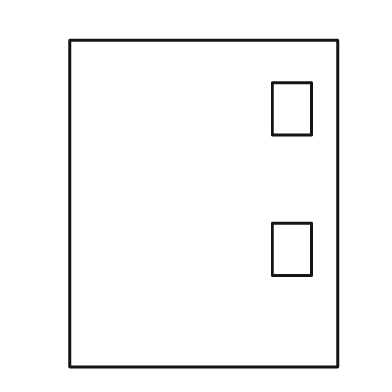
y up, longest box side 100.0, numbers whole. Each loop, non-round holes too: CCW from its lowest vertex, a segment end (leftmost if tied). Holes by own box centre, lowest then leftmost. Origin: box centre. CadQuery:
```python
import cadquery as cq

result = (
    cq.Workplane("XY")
    .moveTo(-41.0, -50.0)
    .lineTo(41.0, -50.0)
    .lineTo(41.0, 50.0)
    .lineTo(-41.0, 50.0)
    .close()
    .moveTo(21.0, -22.0)
    .lineTo(33.0, -22.0)
    .lineTo(33.0, -6.0)
    .lineTo(21.0, -6.0)
    .close()
    .moveTo(21.0, 21.0)
    .lineTo(33.0, 21.0)
    .lineTo(33.0, 37.0)
    .lineTo(21.0, 37.0)
    .close()
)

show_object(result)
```